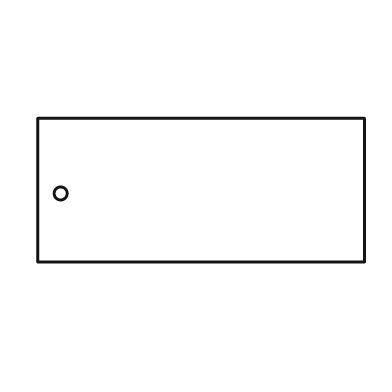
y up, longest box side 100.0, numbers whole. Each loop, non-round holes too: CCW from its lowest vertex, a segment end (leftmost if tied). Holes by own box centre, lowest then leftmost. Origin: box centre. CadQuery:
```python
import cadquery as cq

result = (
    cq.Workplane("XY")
    .moveTo(-50.0, -22.0)
    .lineTo(50.0, -22.0)
    .lineTo(50.0, 22.0)
    .lineTo(-50.0, 22.0)
    .close()
    .moveTo(-43.0, -1.0)
    .circle(2.0)
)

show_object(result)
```